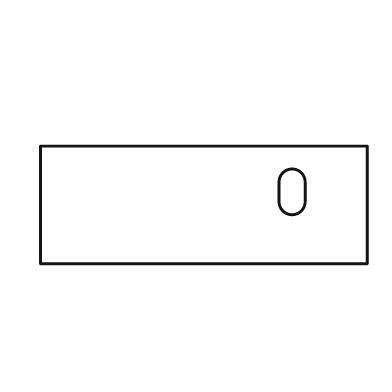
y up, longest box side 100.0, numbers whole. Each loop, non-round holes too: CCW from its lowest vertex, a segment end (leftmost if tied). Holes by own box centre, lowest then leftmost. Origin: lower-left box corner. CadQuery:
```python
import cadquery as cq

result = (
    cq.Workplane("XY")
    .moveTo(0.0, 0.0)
    .lineTo(100.0, 0.0)
    .lineTo(100.0, 36.0)
    .lineTo(0.0, 36.0)
    .close()
    .moveTo(73.0, 19.0)
    .threePointArc((77.0, 15.0), (81.0, 19.0))
    .lineTo(81.0, 25.0)
    .threePointArc((77.0, 29.0), (73.0, 25.0))
    .close()
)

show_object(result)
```